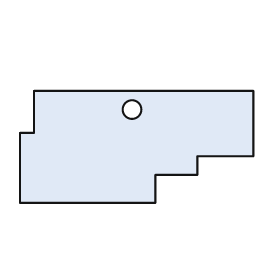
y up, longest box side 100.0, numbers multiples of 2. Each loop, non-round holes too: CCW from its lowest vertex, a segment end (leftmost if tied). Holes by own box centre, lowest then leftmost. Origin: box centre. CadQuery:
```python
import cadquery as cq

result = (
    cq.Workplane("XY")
    .moveTo(-50.0, -24.0)
    .lineTo(8.0, -24.0)
    .lineTo(8.0, -12.0)
    .lineTo(26.0, -12.0)
    .lineTo(26.0, -4.0)
    .lineTo(50.0, -4.0)
    .lineTo(50.0, 24.0)
    .lineTo(-44.0, 24.0)
    .lineTo(-44.0, 6.0)
    .lineTo(-50.0, 6.0)
    .close()
    .moveTo(-2.0, 16.0)
    .circle(4.0)
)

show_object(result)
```